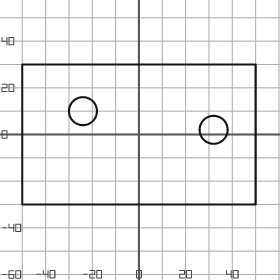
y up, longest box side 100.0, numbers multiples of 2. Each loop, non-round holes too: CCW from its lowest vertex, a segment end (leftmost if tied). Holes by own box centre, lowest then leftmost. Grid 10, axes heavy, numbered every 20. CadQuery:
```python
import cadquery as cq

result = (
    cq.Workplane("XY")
    .moveTo(-50.0, -30.0)
    .lineTo(50.0, -30.0)
    .lineTo(50.0, 30.0)
    .lineTo(-50.0, 30.0)
    .close()
    .moveTo(32.0, 2.0)
    .circle(6.0)
    .moveTo(-24.0, 10.0)
    .circle(6.0)
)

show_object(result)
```